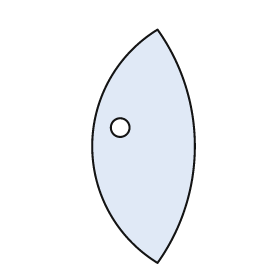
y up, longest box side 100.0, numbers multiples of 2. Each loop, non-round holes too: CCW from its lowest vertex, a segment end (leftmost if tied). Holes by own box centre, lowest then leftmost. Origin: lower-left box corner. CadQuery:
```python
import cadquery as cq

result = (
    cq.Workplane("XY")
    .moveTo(28.0, 0.0)
    .threePointArc((44.0, 50.0), (28.0, 100.0))
    .threePointArc((0.0, 50.0), (28.0, 0.0))
    .close()
    .moveTo(12.0, 58.0)
    .circle(4.0)
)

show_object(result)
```